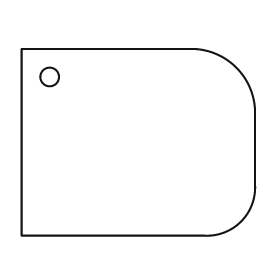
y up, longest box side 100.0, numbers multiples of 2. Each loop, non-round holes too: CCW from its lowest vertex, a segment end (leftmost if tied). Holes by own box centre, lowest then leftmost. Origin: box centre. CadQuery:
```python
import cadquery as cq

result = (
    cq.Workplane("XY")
    .moveTo(-50.0, -40.0)
    .lineTo(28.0, -40.0)
    .threePointArc((44.0, -34.0), (50.0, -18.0))
    .lineTo(50.0, 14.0)
    .threePointArc((42.0, 32.0), (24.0, 40.0))
    .lineTo(-50.0, 40.0)
    .close()
    .moveTo(-38.0, 28.0)
    .circle(4.0)
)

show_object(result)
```